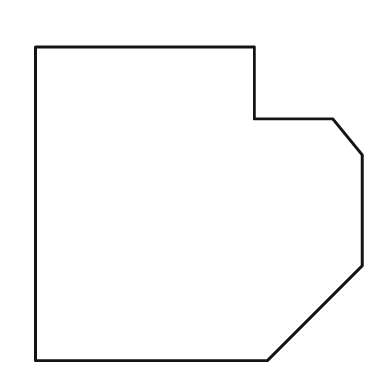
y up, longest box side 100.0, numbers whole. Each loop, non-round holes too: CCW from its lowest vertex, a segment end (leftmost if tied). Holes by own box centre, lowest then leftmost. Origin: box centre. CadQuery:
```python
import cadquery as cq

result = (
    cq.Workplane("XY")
    .moveTo(-50.0, -48.0)
    .lineTo(21.0, -48.0)
    .lineTo(50.0, -19.0)
    .lineTo(50.0, 15.0)
    .lineTo(41.0, 26.0)
    .lineTo(17.0, 26.0)
    .lineTo(17.0, 48.0)
    .lineTo(-50.0, 48.0)
    .close()
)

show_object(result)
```